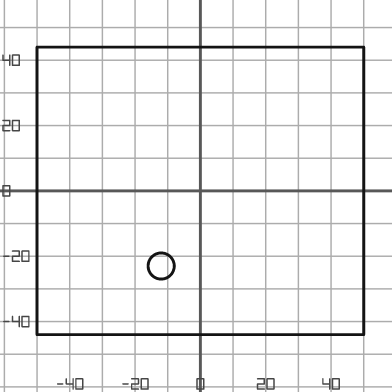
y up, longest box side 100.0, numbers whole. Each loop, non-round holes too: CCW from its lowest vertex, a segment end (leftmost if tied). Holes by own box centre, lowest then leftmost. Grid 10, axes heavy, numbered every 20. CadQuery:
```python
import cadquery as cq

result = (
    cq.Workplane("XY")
    .moveTo(-50.0, -44.0)
    .lineTo(50.0, -44.0)
    .lineTo(50.0, 44.0)
    .lineTo(-50.0, 44.0)
    .close()
    .moveTo(-12.0, -23.0)
    .circle(4.0)
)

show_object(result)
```